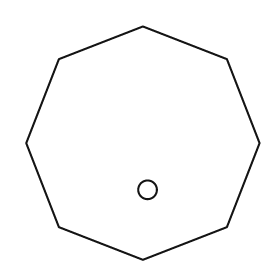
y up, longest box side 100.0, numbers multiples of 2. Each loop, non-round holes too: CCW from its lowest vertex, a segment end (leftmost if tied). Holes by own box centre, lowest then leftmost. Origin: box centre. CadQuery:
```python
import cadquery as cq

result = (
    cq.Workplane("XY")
    .moveTo(0.0, -50.0)
    .lineTo(36.0, -36.0)
    .lineTo(50.0, 0.0)
    .lineTo(36.0, 36.0)
    .lineTo(0.0, 50.0)
    .lineTo(-36.0, 36.0)
    .lineTo(-50.0, 0.0)
    .lineTo(-36.0, -36.0)
    .close()
    .moveTo(2.0, -20.0)
    .circle(4.0)
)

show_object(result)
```